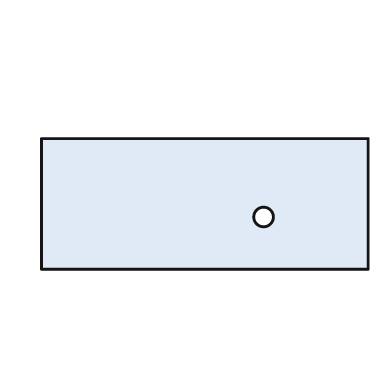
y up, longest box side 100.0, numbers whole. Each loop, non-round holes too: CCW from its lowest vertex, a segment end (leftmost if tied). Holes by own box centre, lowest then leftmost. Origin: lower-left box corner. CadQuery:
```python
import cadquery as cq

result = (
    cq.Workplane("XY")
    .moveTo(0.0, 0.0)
    .lineTo(100.0, 0.0)
    .lineTo(100.0, 40.0)
    .lineTo(0.0, 40.0)
    .close()
    .moveTo(68.0, 16.0)
    .circle(3.0)
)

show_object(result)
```